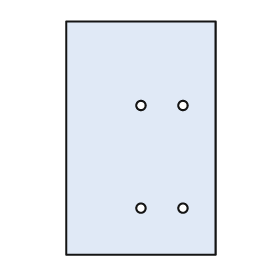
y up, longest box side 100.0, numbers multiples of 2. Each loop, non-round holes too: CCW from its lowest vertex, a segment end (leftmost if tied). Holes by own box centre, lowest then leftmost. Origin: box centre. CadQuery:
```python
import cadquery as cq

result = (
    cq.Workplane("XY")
    .moveTo(-32.0, -50.0)
    .lineTo(32.0, -50.0)
    .lineTo(32.0, 50.0)
    .lineTo(-32.0, 50.0)
    .close()
    .moveTo(0.0, -30.0)
    .circle(2.0)
    .moveTo(18.0, -30.0)
    .circle(2.0)
    .moveTo(0.0, 14.0)
    .circle(2.0)
    .moveTo(18.0, 14.0)
    .circle(2.0)
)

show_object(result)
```